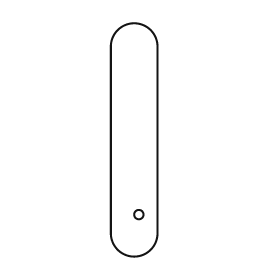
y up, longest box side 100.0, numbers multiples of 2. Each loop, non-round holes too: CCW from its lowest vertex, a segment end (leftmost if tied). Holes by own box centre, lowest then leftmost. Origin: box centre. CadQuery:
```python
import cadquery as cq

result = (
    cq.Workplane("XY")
    .moveTo(-10.0, -40.0)
    .threePointArc((0.0, -50.0), (10.0, -40.0))
    .lineTo(10.0, 40.0)
    .threePointArc((0.0, 50.0), (-10.0, 40.0))
    .close()
    .moveTo(2.0, -32.0)
    .circle(2.0)
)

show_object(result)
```